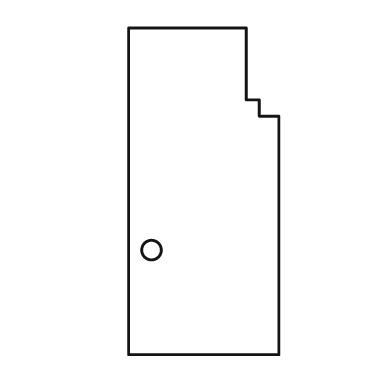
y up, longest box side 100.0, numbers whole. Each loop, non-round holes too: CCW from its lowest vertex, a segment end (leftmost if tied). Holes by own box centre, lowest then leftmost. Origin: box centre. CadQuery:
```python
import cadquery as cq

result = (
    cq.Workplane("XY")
    .moveTo(-23.0, -50.0)
    .lineTo(23.0, -50.0)
    .lineTo(23.0, 23.0)
    .lineTo(17.0, 23.0)
    .lineTo(17.0, 28.0)
    .lineTo(13.0, 28.0)
    .lineTo(13.0, 50.0)
    .lineTo(-23.0, 50.0)
    .close()
    .moveTo(-16.0, -18.0)
    .circle(3.0)
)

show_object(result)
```